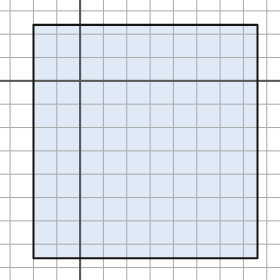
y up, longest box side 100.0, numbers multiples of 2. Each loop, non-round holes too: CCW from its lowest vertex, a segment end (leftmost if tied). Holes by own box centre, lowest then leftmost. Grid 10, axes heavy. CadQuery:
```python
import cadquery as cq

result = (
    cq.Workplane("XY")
    .moveTo(-20.0, -76.0)
    .lineTo(76.0, -76.0)
    .lineTo(76.0, 24.0)
    .lineTo(-20.0, 24.0)
    .close()
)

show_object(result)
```